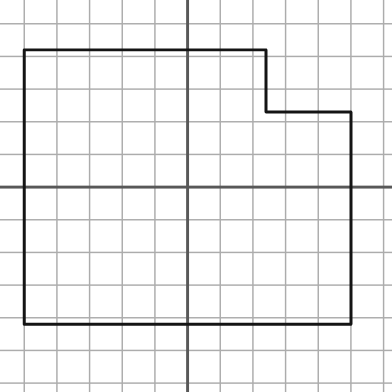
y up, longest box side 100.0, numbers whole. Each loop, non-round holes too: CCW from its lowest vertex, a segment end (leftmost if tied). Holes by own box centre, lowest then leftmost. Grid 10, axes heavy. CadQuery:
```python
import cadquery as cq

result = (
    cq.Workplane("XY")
    .moveTo(-50.0, -42.0)
    .lineTo(50.0, -42.0)
    .lineTo(50.0, 23.0)
    .lineTo(24.0, 23.0)
    .lineTo(24.0, 42.0)
    .lineTo(-50.0, 42.0)
    .close()
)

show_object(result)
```